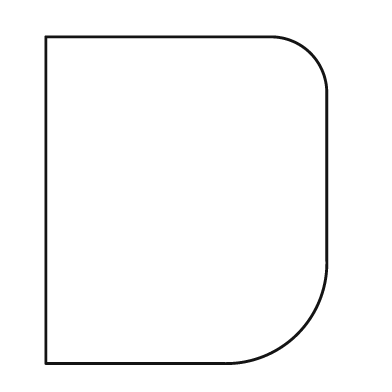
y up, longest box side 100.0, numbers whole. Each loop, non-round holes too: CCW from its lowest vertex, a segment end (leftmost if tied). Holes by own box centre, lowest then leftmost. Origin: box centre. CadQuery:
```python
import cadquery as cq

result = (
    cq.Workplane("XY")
    .moveTo(-43.0, -50.0)
    .lineTo(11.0, -50.0)
    .threePointArc((34.0, -41.0), (43.0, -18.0))
    .lineTo(43.0, 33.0)
    .threePointArc((38.0, 45.0), (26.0, 50.0))
    .lineTo(-43.0, 50.0)
    .close()
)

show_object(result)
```